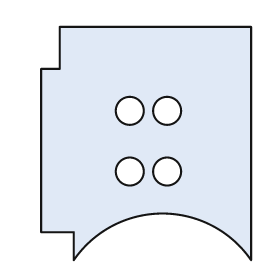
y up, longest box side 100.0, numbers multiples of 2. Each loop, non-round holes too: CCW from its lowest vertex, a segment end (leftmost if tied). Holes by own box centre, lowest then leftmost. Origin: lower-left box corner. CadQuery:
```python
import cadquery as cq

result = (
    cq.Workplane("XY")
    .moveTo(14.0, 0.0)
    .threePointArc((52.0, 20.0), (90.0, 0.0))
    .lineTo(90.0, 100.0)
    .lineTo(8.0, 100.0)
    .lineTo(8.0, 82.0)
    .lineTo(0.0, 82.0)
    .lineTo(0.0, 12.0)
    .lineTo(14.0, 12.0)
    .close()
    .moveTo(38.0, 38.0)
    .circle(6.0)
    .moveTo(54.0, 38.0)
    .circle(6.0)
    .moveTo(38.0, 64.0)
    .circle(6.0)
    .moveTo(54.0, 64.0)
    .circle(6.0)
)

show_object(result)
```